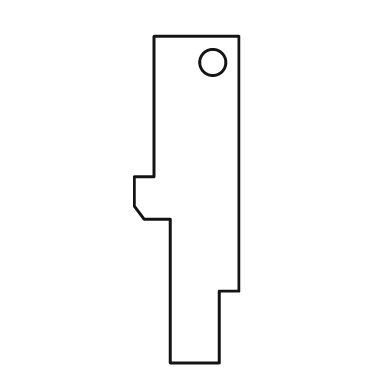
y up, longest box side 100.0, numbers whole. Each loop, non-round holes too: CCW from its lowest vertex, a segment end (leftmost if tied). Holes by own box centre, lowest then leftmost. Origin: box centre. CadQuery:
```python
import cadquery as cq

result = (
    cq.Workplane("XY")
    .moveTo(-5.0, -50.0)
    .lineTo(10.0, -50.0)
    .lineTo(10.0, -28.0)
    .lineTo(16.0, -28.0)
    .lineTo(16.0, 50.0)
    .lineTo(-10.0, 50.0)
    .lineTo(-10.0, 7.0)
    .lineTo(-16.0, 7.0)
    .lineTo(-16.0, -2.0)
    .lineTo(-13.0, -6.0)
    .lineTo(-5.0, -6.0)
    .close()
    .moveTo(8.0, 42.0)
    .circle(4.0)
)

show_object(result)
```